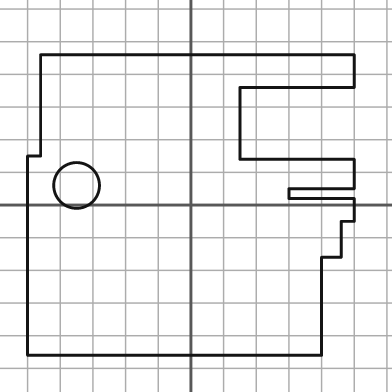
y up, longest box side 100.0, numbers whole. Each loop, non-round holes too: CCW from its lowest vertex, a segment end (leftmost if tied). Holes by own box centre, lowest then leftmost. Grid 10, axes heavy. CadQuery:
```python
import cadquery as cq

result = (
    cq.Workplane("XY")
    .moveTo(-50.0, -46.0)
    .lineTo(40.0, -46.0)
    .lineTo(40.0, -16.0)
    .lineTo(46.0, -16.0)
    .lineTo(46.0, -5.0)
    .lineTo(50.0, -5.0)
    .lineTo(50.0, 2.0)
    .lineTo(30.0, 2.0)
    .lineTo(30.0, 5.0)
    .lineTo(50.0, 5.0)
    .lineTo(50.0, 14.0)
    .lineTo(15.0, 14.0)
    .lineTo(15.0, 36.0)
    .lineTo(50.0, 36.0)
    .lineTo(50.0, 46.0)
    .lineTo(-46.0, 46.0)
    .lineTo(-46.0, 15.0)
    .lineTo(-50.0, 15.0)
    .close()
    .moveTo(-35.0, 6.0)
    .circle(7.0)
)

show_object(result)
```